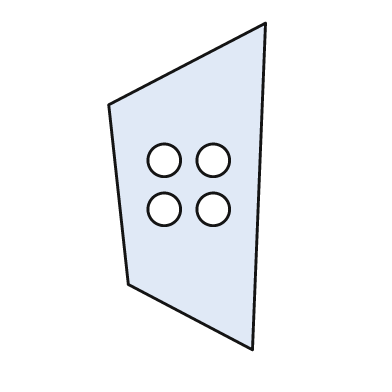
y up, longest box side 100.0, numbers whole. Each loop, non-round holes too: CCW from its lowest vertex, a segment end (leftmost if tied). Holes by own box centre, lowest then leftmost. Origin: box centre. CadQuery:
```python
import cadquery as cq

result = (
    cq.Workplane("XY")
    .moveTo(20.0, -50.0)
    .lineTo(24.0, 50.0)
    .lineTo(-24.0, 25.0)
    .lineTo(-18.0, -30.0)
    .close()
    .moveTo(-7.0, -7.0)
    .circle(5.0)
    .moveTo(8.0, -7.0)
    .circle(5.0)
    .moveTo(-7.0, 8.0)
    .circle(5.0)
    .moveTo(8.0, 8.0)
    .circle(5.0)
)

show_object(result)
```